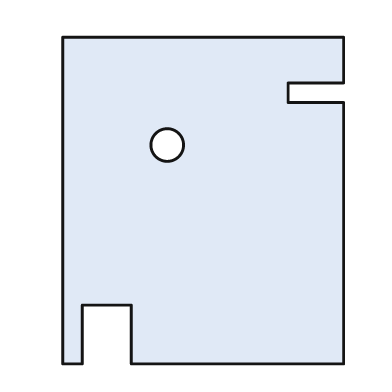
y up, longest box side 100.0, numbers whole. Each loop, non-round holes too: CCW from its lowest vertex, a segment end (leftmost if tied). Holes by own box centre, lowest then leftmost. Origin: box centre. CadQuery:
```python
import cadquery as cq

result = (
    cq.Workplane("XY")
    .moveTo(-43.0, -50.0)
    .lineTo(-37.0, -50.0)
    .lineTo(-37.0, -32.0)
    .lineTo(-22.0, -32.0)
    .lineTo(-22.0, -50.0)
    .lineTo(43.0, -50.0)
    .lineTo(43.0, 30.0)
    .lineTo(26.0, 30.0)
    .lineTo(26.0, 36.0)
    .lineTo(43.0, 36.0)
    .lineTo(43.0, 50.0)
    .lineTo(-43.0, 50.0)
    .close()
    .moveTo(-11.0, 17.0)
    .circle(5.0)
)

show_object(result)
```